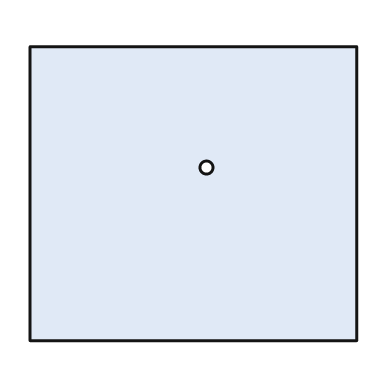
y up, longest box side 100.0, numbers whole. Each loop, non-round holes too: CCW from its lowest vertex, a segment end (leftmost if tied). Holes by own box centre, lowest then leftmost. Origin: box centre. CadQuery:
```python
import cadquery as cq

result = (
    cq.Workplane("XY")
    .moveTo(-50.0, -45.0)
    .lineTo(50.0, -45.0)
    .lineTo(50.0, 45.0)
    .lineTo(-50.0, 45.0)
    .close()
    .moveTo(4.0, 8.0)
    .circle(2.0)
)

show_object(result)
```